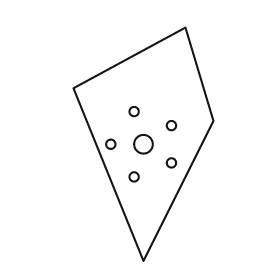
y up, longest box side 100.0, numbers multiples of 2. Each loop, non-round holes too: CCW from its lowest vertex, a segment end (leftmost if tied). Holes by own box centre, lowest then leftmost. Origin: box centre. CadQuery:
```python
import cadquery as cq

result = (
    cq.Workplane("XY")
    .moveTo(0.0, -50.0)
    .lineTo(30.0, 10.0)
    .lineTo(18.0, 50.0)
    .lineTo(-30.0, 24.0)
    .close()
    .moveTo(-4.0, -14.0)
    .circle(2.0)
    .moveTo(12.0, -8.0)
    .circle(2.0)
    .moveTo(-14.0, 0.0)
    .circle(2.0)
    .moveTo(0.0, 0.0)
    .circle(4.0)
    .moveTo(12.0, 8.0)
    .circle(2.0)
    .moveTo(-4.0, 14.0)
    .circle(2.0)
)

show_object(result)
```